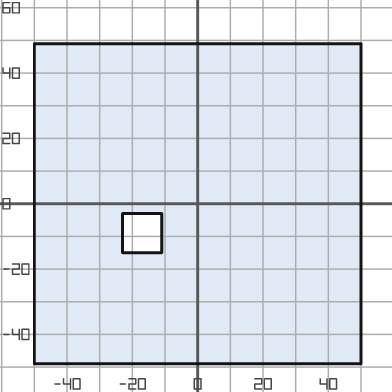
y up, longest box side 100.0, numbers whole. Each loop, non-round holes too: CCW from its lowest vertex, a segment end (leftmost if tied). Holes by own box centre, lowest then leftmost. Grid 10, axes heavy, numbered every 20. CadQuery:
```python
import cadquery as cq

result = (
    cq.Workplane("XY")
    .moveTo(-50.0, -49.0)
    .lineTo(50.0, -49.0)
    .lineTo(50.0, 49.0)
    .lineTo(-50.0, 49.0)
    .close()
    .moveTo(-23.0, -15.0)
    .lineTo(-11.0, -15.0)
    .lineTo(-11.0, -3.0)
    .lineTo(-23.0, -3.0)
    .close()
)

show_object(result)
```